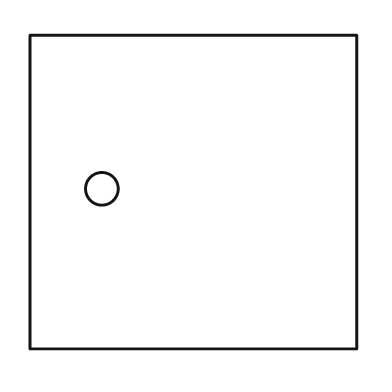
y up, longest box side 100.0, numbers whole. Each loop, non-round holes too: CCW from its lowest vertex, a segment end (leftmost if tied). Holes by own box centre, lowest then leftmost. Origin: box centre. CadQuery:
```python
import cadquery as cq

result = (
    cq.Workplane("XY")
    .moveTo(-50.0, -48.0)
    .lineTo(50.0, -48.0)
    .lineTo(50.0, 48.0)
    .lineTo(-50.0, 48.0)
    .close()
    .moveTo(-28.0, 1.0)
    .circle(5.0)
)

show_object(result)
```